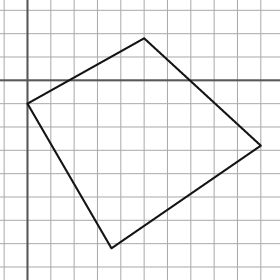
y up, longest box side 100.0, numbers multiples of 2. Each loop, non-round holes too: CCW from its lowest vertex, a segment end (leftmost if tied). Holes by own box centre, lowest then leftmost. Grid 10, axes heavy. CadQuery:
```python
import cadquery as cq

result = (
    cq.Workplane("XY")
    .moveTo(36.0, -72.0)
    .lineTo(100.0, -28.0)
    .lineTo(50.0, 18.0)
    .lineTo(0.0, -10.0)
    .close()
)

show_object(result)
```